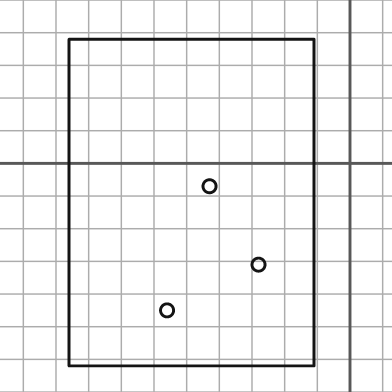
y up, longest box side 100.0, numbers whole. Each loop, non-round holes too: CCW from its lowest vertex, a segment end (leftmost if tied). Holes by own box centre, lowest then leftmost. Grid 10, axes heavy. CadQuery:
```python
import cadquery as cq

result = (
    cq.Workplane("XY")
    .moveTo(-86.0, -62.0)
    .lineTo(-11.0, -62.0)
    .lineTo(-11.0, 38.0)
    .lineTo(-86.0, 38.0)
    .close()
    .moveTo(-56.0, -45.0)
    .circle(2.0)
    .moveTo(-28.0, -31.0)
    .circle(2.0)
    .moveTo(-43.0, -7.0)
    .circle(2.0)
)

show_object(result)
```